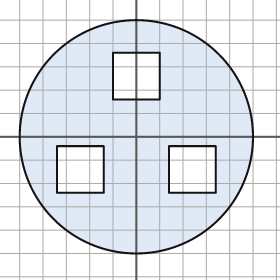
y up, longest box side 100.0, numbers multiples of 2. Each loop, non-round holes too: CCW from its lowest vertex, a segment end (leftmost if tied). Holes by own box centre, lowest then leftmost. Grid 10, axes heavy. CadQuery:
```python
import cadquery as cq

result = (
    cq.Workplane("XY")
    .moveTo(0.0, 0.0)
    .circle(50.0)
    .moveTo(-34.0, -24.0)
    .lineTo(-14.0, -24.0)
    .lineTo(-14.0, -4.0)
    .lineTo(-34.0, -4.0)
    .close()
    .moveTo(14.0, -24.0)
    .lineTo(34.0, -24.0)
    .lineTo(34.0, -4.0)
    .lineTo(14.0, -4.0)
    .close()
    .moveTo(-10.0, 16.0)
    .lineTo(10.0, 16.0)
    .lineTo(10.0, 36.0)
    .lineTo(-10.0, 36.0)
    .close()
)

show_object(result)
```